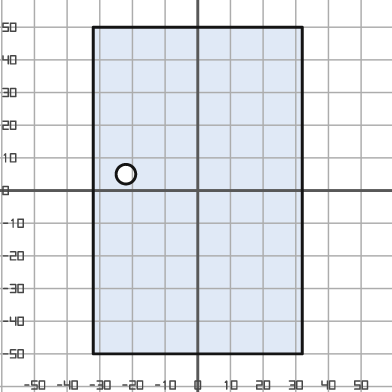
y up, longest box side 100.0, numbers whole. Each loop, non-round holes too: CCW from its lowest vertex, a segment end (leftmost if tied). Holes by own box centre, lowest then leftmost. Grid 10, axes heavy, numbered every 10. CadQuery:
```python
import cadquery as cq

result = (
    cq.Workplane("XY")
    .moveTo(-32.0, -50.0)
    .lineTo(32.0, -50.0)
    .lineTo(32.0, 50.0)
    .lineTo(-32.0, 50.0)
    .close()
    .moveTo(-22.0, 5.0)
    .circle(3.0)
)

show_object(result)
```